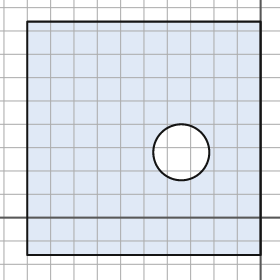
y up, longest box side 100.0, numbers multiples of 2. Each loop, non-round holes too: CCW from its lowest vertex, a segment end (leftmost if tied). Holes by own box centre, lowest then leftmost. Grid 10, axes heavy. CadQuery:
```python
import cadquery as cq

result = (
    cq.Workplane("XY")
    .moveTo(-100.0, -16.0)
    .lineTo(0.0, -16.0)
    .lineTo(0.0, 84.0)
    .lineTo(-100.0, 84.0)
    .close()
    .moveTo(-34.0, 28.0)
    .circle(12.0)
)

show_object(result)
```